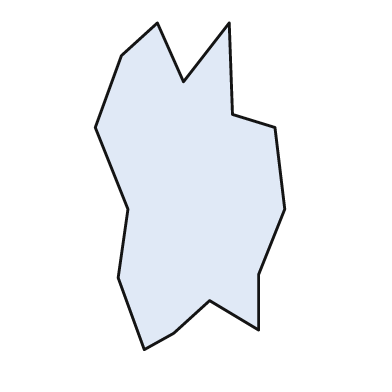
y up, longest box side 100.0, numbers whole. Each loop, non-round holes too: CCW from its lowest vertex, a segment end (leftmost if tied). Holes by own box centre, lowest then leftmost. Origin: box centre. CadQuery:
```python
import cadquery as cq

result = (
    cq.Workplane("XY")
    .moveTo(-14.0, -50.0)
    .lineTo(-5.0, -45.0)
    .lineTo(6.0, -35.0)
    .lineTo(21.0, -44.0)
    .lineTo(21.0, -27.0)
    .lineTo(29.0, -7.0)
    .lineTo(26.0, 18.0)
    .lineTo(13.0, 22.0)
    .lineTo(12.0, 50.0)
    .lineTo(-2.0, 32.0)
    .lineTo(-10.0, 50.0)
    .lineTo(-21.0, 40.0)
    .lineTo(-29.0, 18.0)
    .lineTo(-19.0, -7.0)
    .lineTo(-22.0, -28.0)
    .close()
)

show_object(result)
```